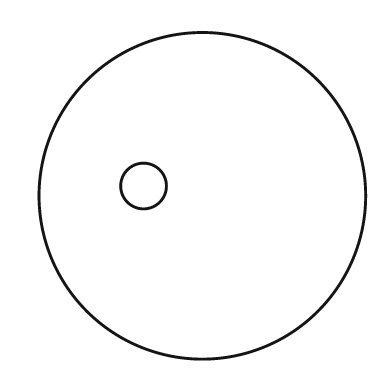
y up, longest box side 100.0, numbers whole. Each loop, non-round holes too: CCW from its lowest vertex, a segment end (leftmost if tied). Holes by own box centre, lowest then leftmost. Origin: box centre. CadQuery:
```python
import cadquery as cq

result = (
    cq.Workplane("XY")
    .moveTo(0.0, 0.0)
    .circle(50.0)
    .moveTo(-18.0, 3.0)
    .circle(7.0)
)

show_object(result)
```